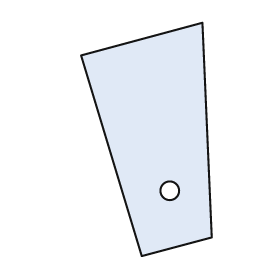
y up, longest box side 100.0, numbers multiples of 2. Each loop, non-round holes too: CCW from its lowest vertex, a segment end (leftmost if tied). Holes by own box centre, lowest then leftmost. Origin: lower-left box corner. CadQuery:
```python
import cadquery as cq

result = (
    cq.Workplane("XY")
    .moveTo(26.0, 0.0)
    .lineTo(56.0, 8.0)
    .lineTo(52.0, 100.0)
    .lineTo(0.0, 86.0)
    .close()
    .moveTo(38.0, 28.0)
    .circle(4.0)
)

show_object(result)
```